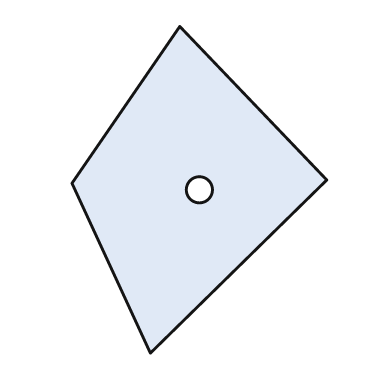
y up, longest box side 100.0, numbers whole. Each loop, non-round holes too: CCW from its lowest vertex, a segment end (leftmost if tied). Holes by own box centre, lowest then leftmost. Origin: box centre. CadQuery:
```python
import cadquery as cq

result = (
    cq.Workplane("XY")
    .moveTo(-15.0, -50.0)
    .lineTo(39.0, 3.0)
    .lineTo(-6.0, 50.0)
    .lineTo(-39.0, 2.0)
    .close()
    .moveTo(0.0, 0.0)
    .circle(4.0)
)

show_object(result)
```